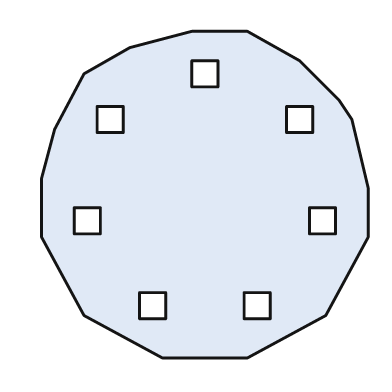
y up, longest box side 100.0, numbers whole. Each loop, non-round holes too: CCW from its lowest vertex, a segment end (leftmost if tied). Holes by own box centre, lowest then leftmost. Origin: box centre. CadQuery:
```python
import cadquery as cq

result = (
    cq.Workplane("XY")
    .moveTo(-13.0, -50.0)
    .lineTo(13.0, -50.0)
    .lineTo(37.0, -37.0)
    .lineTo(50.0, -13.0)
    .lineTo(50.0, 2.0)
    .lineTo(45.0, 23.0)
    .lineTo(41.0, 29.0)
    .lineTo(29.0, 41.0)
    .lineTo(13.0, 50.0)
    .lineTo(-4.0, 50.0)
    .lineTo(-23.0, 45.0)
    .lineTo(-37.0, 37.0)
    .lineTo(-46.0, 20.0)
    .lineTo(-50.0, 5.0)
    .lineTo(-50.0, -13.0)
    .lineTo(-37.0, -37.0)
    .close()
    .moveTo(-20.0, -38.0)
    .lineTo(-12.0, -38.0)
    .lineTo(-12.0, -30.0)
    .lineTo(-20.0, -30.0)
    .close()
    .moveTo(12.0, -38.0)
    .lineTo(20.0, -38.0)
    .lineTo(20.0, -30.0)
    .lineTo(12.0, -30.0)
    .close()
    .moveTo(-40.0, -12.0)
    .lineTo(-32.0, -12.0)
    .lineTo(-32.0, -4.0)
    .lineTo(-40.0, -4.0)
    .close()
    .moveTo(32.0, -12.0)
    .lineTo(40.0, -12.0)
    .lineTo(40.0, -4.0)
    .lineTo(32.0, -4.0)
    .close()
    .moveTo(-33.0, 19.0)
    .lineTo(-25.0, 19.0)
    .lineTo(-25.0, 27.0)
    .lineTo(-33.0, 27.0)
    .close()
    .moveTo(25.0, 19.0)
    .lineTo(33.0, 19.0)
    .lineTo(33.0, 27.0)
    .lineTo(25.0, 27.0)
    .close()
    .moveTo(-4.0, 33.0)
    .lineTo(4.0, 33.0)
    .lineTo(4.0, 41.0)
    .lineTo(-4.0, 41.0)
    .close()
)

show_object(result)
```